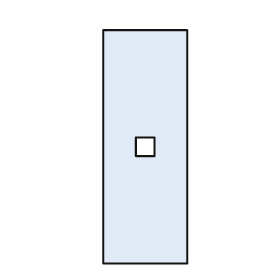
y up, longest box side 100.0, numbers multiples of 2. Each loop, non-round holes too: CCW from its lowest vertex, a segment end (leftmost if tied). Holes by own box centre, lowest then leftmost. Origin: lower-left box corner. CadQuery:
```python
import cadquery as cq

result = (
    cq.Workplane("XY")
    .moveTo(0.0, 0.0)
    .lineTo(36.0, 0.0)
    .lineTo(36.0, 100.0)
    .lineTo(0.0, 100.0)
    .close()
    .moveTo(14.0, 46.0)
    .lineTo(22.0, 46.0)
    .lineTo(22.0, 54.0)
    .lineTo(14.0, 54.0)
    .close()
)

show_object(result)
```